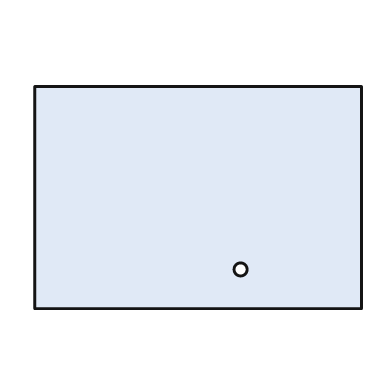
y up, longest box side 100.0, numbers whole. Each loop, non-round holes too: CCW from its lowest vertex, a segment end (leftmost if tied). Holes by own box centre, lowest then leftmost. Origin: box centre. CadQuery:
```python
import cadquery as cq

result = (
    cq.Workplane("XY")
    .moveTo(-50.0, -34.0)
    .lineTo(50.0, -34.0)
    .lineTo(50.0, 34.0)
    .lineTo(-50.0, 34.0)
    .close()
    .moveTo(13.0, -22.0)
    .circle(2.0)
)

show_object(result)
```